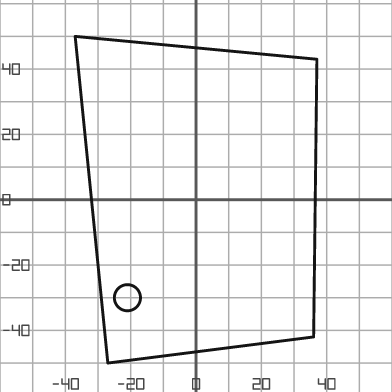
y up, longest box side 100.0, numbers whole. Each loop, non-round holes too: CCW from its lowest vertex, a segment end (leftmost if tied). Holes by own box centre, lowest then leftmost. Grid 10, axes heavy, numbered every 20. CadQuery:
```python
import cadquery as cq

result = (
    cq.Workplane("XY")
    .moveTo(-27.0, -50.0)
    .lineTo(36.0, -42.0)
    .lineTo(37.0, 43.0)
    .lineTo(-37.0, 50.0)
    .close()
    .moveTo(-21.0, -30.0)
    .circle(4.0)
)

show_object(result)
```